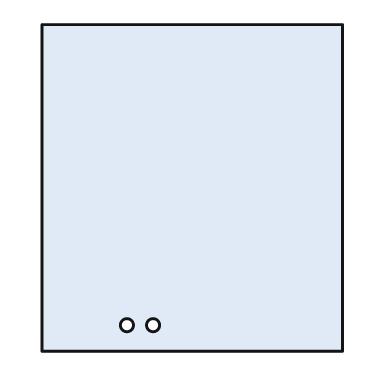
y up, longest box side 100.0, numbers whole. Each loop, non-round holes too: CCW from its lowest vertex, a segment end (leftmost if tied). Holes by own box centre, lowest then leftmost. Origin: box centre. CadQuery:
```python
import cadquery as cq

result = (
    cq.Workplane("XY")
    .moveTo(-46.0, -50.0)
    .lineTo(46.0, -50.0)
    .lineTo(46.0, 50.0)
    .lineTo(-46.0, 50.0)
    .close()
    .moveTo(-20.0, -42.0)
    .circle(2.0)
    .moveTo(-12.0, -42.0)
    .circle(2.0)
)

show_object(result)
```